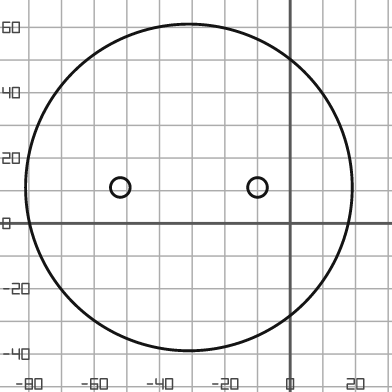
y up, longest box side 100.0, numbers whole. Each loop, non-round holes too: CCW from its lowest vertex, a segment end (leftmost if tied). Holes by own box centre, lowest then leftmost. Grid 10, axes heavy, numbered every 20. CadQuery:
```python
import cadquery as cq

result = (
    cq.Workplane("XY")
    .moveTo(-31.0, 11.0)
    .circle(50.0)
    .moveTo(-52.0, 11.0)
    .circle(3.0)
    .moveTo(-10.0, 11.0)
    .circle(3.0)
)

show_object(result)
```